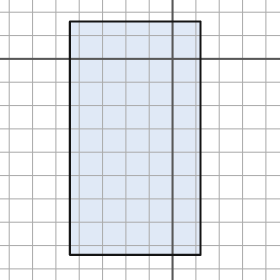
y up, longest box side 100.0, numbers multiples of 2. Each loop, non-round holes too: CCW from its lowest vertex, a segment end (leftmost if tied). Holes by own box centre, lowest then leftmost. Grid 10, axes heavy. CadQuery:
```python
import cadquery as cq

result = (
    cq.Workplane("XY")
    .moveTo(-44.0, -84.0)
    .lineTo(12.0, -84.0)
    .lineTo(12.0, 16.0)
    .lineTo(-44.0, 16.0)
    .close()
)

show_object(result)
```